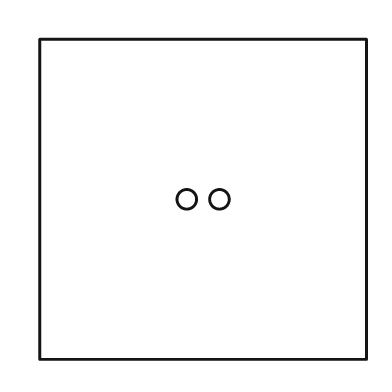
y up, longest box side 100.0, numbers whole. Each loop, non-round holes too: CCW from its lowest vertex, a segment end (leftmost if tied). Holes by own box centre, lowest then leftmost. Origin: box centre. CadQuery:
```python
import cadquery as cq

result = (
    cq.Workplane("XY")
    .moveTo(-50.0, -49.0)
    .lineTo(50.0, -49.0)
    .lineTo(50.0, 49.0)
    .lineTo(-50.0, 49.0)
    .close()
    .moveTo(-5.0, 0.0)
    .circle(3.0)
    .moveTo(5.0, 0.0)
    .circle(3.0)
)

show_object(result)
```